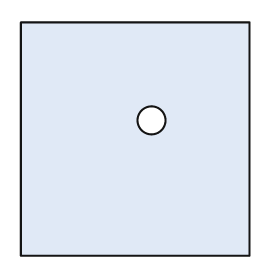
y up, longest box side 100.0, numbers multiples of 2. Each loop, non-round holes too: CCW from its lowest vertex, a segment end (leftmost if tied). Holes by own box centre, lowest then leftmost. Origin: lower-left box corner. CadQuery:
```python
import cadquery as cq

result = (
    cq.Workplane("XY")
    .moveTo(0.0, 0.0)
    .lineTo(98.0, 0.0)
    .lineTo(98.0, 100.0)
    .lineTo(0.0, 100.0)
    .close()
    .moveTo(56.0, 58.0)
    .circle(6.0)
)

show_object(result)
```